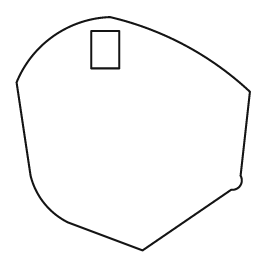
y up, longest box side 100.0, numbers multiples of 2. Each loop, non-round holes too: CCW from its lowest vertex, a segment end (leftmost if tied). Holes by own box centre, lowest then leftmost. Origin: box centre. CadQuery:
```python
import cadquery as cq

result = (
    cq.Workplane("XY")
    .moveTo(4.0, -50.0)
    .lineTo(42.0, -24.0)
    .threePointArc((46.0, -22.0), (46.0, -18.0))
    .lineTo(50.0, 18.0)
    .threePointArc((22.0, 38.0), (-10.0, 50.0))
    .threePointArc((-34.0, 42.0), (-50.0, 22.0))
    .lineTo(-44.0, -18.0)
    .threePointArc((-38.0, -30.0), (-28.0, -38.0))
    .close()
    .moveTo(-18.0, 28.0)
    .lineTo(-6.0, 28.0)
    .lineTo(-6.0, 44.0)
    .lineTo(-18.0, 44.0)
    .close()
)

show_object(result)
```